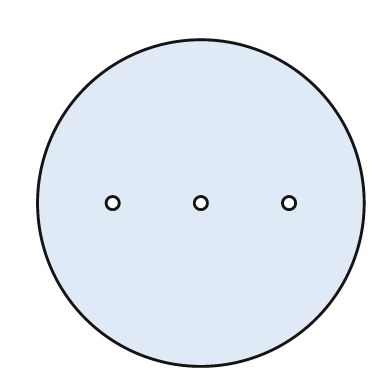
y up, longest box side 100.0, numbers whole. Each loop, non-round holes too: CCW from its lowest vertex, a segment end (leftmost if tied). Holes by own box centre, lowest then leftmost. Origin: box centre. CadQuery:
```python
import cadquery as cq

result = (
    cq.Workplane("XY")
    .moveTo(0.0, 0.0)
    .circle(50.0)
    .moveTo(-27.0, 0.0)
    .circle(2.0)
    .moveTo(0.0, 0.0)
    .circle(2.0)
    .moveTo(27.0, 0.0)
    .circle(2.0)
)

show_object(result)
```